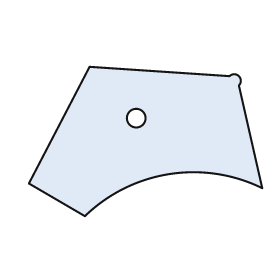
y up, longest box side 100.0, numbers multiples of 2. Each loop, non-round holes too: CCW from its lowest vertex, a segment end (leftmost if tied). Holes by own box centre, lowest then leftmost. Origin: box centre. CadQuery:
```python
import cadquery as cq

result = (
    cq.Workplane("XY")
    .moveTo(-26.0, -32.0)
    .threePointArc((10.0, -14.0), (50.0, -20.0))
    .lineTo(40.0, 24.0)
    .threePointArc((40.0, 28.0), (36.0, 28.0))
    .lineTo(-24.0, 32.0)
    .lineTo(-50.0, -18.0)
    .close()
    .moveTo(-4.0, 10.0)
    .circle(4.0)
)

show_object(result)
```